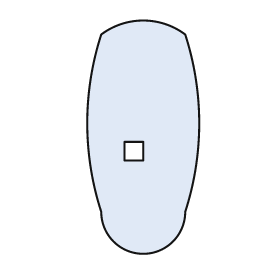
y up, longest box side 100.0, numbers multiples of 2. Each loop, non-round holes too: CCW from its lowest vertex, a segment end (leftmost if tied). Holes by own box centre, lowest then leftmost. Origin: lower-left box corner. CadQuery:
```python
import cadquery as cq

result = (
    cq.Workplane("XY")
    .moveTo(6.0, 18.0)
    .threePointArc((24.0, 0.0), (42.0, 18.0))
    .threePointArc((48.0, 56.0), (42.0, 94.0))
    .threePointArc((24.0, 100.0), (6.0, 94.0))
    .threePointArc((0.0, 56.0), (6.0, 18.0))
    .close()
    .moveTo(16.0, 40.0)
    .lineTo(24.0, 40.0)
    .lineTo(24.0, 48.0)
    .lineTo(16.0, 48.0)
    .close()
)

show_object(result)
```